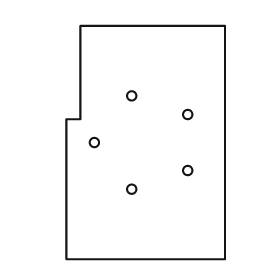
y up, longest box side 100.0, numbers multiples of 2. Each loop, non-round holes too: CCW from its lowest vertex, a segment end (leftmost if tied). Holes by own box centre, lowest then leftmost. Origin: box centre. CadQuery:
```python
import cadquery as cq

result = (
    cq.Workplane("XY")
    .moveTo(-34.0, -50.0)
    .lineTo(34.0, -50.0)
    .lineTo(34.0, 50.0)
    .lineTo(-28.0, 50.0)
    .lineTo(-28.0, 10.0)
    .lineTo(-34.0, 10.0)
    .close()
    .moveTo(-6.0, -20.0)
    .circle(2.0)
    .moveTo(18.0, -12.0)
    .circle(2.0)
    .moveTo(-22.0, 0.0)
    .circle(2.0)
    .moveTo(18.0, 12.0)
    .circle(2.0)
    .moveTo(-6.0, 20.0)
    .circle(2.0)
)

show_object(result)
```